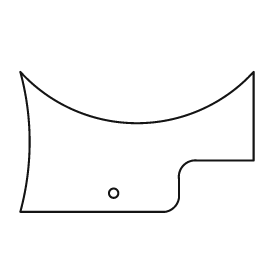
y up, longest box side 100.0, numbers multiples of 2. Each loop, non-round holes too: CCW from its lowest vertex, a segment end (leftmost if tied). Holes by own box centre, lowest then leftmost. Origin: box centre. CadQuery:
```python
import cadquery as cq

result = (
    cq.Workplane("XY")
    .moveTo(-50.0, -30.0)
    .lineTo(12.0, -30.0)
    .threePointArc((16.0, -28.0), (18.0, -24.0))
    .lineTo(18.0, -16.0)
    .threePointArc((20.0, -10.0), (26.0, -8.0))
    .lineTo(50.0, -8.0)
    .lineTo(50.0, 30.0)
    .threePointArc((0.0, 8.0), (-50.0, 30.0))
    .threePointArc((-46.0, 0.0), (-50.0, -30.0))
    .close()
    .moveTo(-10.0, -22.0)
    .circle(2.0)
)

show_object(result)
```